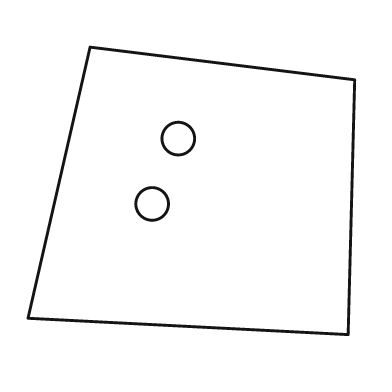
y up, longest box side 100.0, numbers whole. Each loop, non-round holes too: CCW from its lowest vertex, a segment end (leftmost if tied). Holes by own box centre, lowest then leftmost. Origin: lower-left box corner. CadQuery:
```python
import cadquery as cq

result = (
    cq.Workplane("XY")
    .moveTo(98.0, 0.0)
    .lineTo(100.0, 78.0)
    .lineTo(19.0, 88.0)
    .lineTo(0.0, 5.0)
    .close()
    .moveTo(38.0, 40.0)
    .circle(5.0)
    .moveTo(46.0, 60.0)
    .circle(5.0)
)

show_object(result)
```